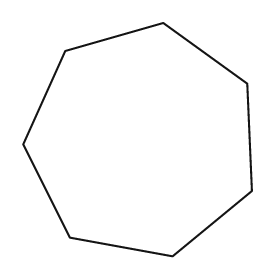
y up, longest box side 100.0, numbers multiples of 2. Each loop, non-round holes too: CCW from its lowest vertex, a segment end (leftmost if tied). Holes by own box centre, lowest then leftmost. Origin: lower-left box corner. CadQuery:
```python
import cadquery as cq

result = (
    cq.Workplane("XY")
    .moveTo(64.0, 0.0)
    .lineTo(98.0, 28.0)
    .lineTo(96.0, 74.0)
    .lineTo(60.0, 100.0)
    .lineTo(18.0, 88.0)
    .lineTo(0.0, 48.0)
    .lineTo(20.0, 8.0)
    .close()
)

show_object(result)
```